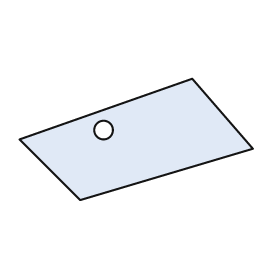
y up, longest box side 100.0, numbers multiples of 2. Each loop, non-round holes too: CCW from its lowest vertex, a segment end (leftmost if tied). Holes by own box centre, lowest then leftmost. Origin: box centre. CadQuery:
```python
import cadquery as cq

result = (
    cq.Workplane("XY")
    .moveTo(-24.0, -26.0)
    .lineTo(50.0, -4.0)
    .lineTo(24.0, 26.0)
    .lineTo(-50.0, 0.0)
    .close()
    .moveTo(-14.0, 4.0)
    .circle(4.0)
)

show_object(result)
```